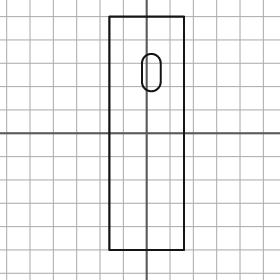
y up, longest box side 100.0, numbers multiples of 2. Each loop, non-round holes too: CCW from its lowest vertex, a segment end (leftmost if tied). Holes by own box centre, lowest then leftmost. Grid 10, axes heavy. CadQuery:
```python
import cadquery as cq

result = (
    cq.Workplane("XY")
    .moveTo(-16.0, -50.0)
    .lineTo(16.0, -50.0)
    .lineTo(16.0, 50.0)
    .lineTo(-16.0, 50.0)
    .close()
    .moveTo(-2.0, 22.0)
    .threePointArc((2.0, 18.0), (6.0, 22.0))
    .lineTo(6.0, 30.0)
    .threePointArc((2.0, 34.0), (-2.0, 30.0))
    .close()
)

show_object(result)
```